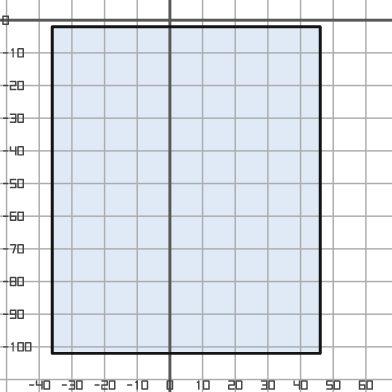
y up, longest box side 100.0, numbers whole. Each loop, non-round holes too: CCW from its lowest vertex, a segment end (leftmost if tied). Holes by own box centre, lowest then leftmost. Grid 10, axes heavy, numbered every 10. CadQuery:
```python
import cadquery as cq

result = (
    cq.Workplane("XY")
    .moveTo(-36.0, -102.0)
    .lineTo(46.0, -102.0)
    .lineTo(46.0, -2.0)
    .lineTo(-36.0, -2.0)
    .close()
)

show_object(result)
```